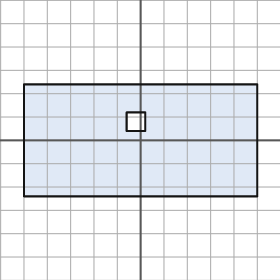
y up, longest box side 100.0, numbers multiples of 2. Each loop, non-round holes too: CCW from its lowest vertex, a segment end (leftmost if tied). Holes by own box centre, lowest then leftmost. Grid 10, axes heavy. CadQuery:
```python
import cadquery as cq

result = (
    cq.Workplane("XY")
    .moveTo(-50.0, -24.0)
    .lineTo(50.0, -24.0)
    .lineTo(50.0, 24.0)
    .lineTo(-50.0, 24.0)
    .close()
    .moveTo(-6.0, 4.0)
    .lineTo(2.0, 4.0)
    .lineTo(2.0, 12.0)
    .lineTo(-6.0, 12.0)
    .close()
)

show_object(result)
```